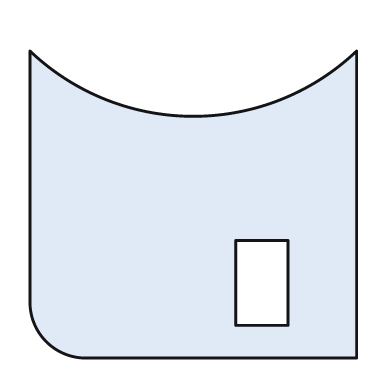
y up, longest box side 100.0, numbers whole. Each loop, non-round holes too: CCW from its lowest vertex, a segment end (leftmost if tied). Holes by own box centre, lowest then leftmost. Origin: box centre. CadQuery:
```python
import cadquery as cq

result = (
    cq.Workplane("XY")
    .moveTo(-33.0, -47.0)
    .lineTo(50.0, -47.0)
    .lineTo(50.0, 47.0)
    .threePointArc((0.0, 27.0), (-50.0, 47.0))
    .lineTo(-50.0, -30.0)
    .threePointArc((-45.0, -42.0), (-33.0, -47.0))
    .close()
    .moveTo(13.0, -37.0)
    .lineTo(29.0, -37.0)
    .lineTo(29.0, -11.0)
    .lineTo(13.0, -11.0)
    .close()
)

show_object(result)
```